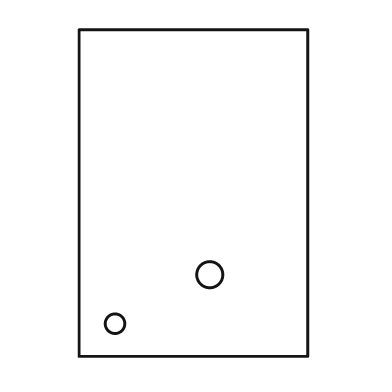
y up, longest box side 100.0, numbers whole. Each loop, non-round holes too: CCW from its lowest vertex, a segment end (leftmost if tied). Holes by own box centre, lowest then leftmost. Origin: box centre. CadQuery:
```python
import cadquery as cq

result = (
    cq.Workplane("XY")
    .moveTo(-35.0, -50.0)
    .lineTo(35.0, -50.0)
    .lineTo(35.0, 50.0)
    .lineTo(-35.0, 50.0)
    .close()
    .moveTo(-24.0, -40.0)
    .circle(3.0)
    .moveTo(5.0, -25.0)
    .circle(4.0)
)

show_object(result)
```